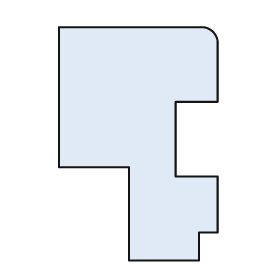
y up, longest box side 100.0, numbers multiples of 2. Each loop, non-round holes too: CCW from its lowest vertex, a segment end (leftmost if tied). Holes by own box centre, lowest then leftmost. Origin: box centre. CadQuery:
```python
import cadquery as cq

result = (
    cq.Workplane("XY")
    .moveTo(-4.0, -50.0)
    .lineTo(26.0, -50.0)
    .lineTo(26.0, -38.0)
    .lineTo(34.0, -38.0)
    .lineTo(34.0, -14.0)
    .lineTo(16.0, -14.0)
    .lineTo(16.0, 18.0)
    .lineTo(34.0, 18.0)
    .lineTo(34.0, 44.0)
    .threePointArc((32.0, 48.0), (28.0, 50.0))
    .lineTo(-34.0, 50.0)
    .lineTo(-34.0, -10.0)
    .lineTo(-4.0, -10.0)
    .close()
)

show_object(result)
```